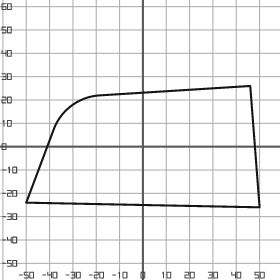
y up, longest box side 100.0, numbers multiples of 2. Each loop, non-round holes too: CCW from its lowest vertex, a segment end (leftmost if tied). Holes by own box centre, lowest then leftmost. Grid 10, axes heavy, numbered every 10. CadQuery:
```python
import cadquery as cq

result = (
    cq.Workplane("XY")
    .moveTo(50.0, -26.0)
    .lineTo(46.0, 26.0)
    .lineTo(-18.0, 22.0)
    .threePointArc((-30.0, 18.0), (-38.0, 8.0))
    .lineTo(-50.0, -24.0)
    .close()
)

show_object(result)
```